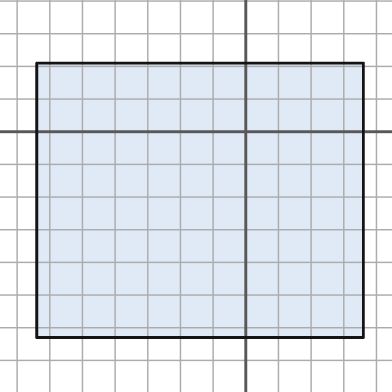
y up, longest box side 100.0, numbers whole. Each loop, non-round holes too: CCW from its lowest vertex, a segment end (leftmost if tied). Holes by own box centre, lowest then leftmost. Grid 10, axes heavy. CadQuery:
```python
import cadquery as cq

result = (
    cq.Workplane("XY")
    .moveTo(-64.0, -63.0)
    .lineTo(36.0, -63.0)
    .lineTo(36.0, 21.0)
    .lineTo(-64.0, 21.0)
    .close()
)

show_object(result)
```